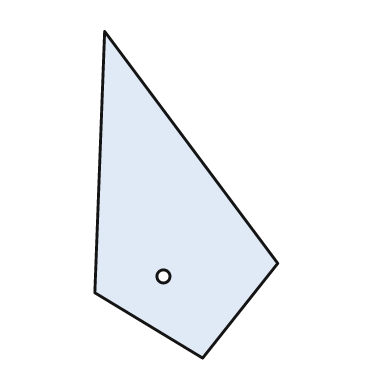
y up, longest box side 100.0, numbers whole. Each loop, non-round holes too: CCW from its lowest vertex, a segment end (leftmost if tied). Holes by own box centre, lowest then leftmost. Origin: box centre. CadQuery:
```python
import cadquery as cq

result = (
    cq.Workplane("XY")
    .moveTo(5.0, -50.0)
    .lineTo(28.0, -21.0)
    .lineTo(-25.0, 50.0)
    .lineTo(-28.0, -30.0)
    .close()
    .moveTo(-7.0, -25.0)
    .circle(2.0)
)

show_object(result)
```